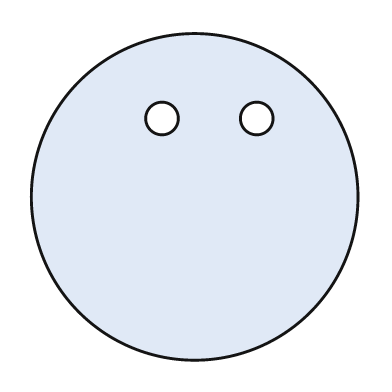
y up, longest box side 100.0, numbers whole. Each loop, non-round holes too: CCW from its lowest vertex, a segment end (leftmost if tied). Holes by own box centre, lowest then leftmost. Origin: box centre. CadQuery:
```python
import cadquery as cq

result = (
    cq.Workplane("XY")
    .moveTo(0.0, 0.0)
    .circle(50.0)
    .moveTo(-10.0, 24.0)
    .circle(5.0)
    .moveTo(19.0, 24.0)
    .circle(5.0)
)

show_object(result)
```